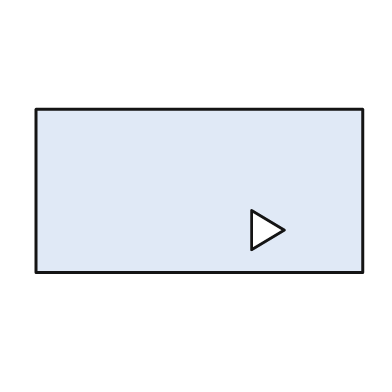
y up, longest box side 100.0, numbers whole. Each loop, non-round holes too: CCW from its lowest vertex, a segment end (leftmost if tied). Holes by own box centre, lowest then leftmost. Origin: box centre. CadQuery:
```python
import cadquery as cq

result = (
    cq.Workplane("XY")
    .moveTo(-50.0, -25.0)
    .lineTo(50.0, -25.0)
    .lineTo(50.0, 25.0)
    .lineTo(-50.0, 25.0)
    .close()
    .moveTo(16.0, -18.0)
    .lineTo(26.0, -12.0)
    .lineTo(16.0, -6.0)
    .close()
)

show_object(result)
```